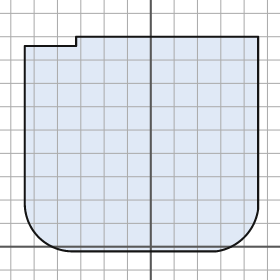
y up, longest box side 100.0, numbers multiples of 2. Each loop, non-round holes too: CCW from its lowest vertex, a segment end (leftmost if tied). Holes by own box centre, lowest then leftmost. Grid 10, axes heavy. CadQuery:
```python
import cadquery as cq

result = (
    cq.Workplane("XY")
    .moveTo(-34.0, -2.0)
    .lineTo(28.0, -2.0)
    .threePointArc((40.0, 4.0), (46.0, 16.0))
    .lineTo(46.0, 90.0)
    .lineTo(-32.0, 90.0)
    .lineTo(-32.0, 86.0)
    .lineTo(-54.0, 86.0)
    .lineTo(-54.0, 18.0)
    .threePointArc((-48.0, 4.0), (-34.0, -2.0))
    .close()
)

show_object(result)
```